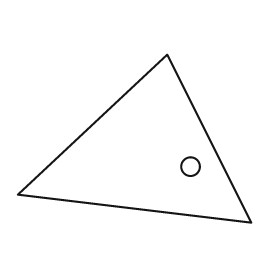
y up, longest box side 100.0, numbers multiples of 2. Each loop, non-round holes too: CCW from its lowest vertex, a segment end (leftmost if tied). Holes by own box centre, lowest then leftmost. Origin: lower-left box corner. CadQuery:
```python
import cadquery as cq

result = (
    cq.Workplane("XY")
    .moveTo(100.0, 0.0)
    .lineTo(64.0, 72.0)
    .lineTo(0.0, 12.0)
    .close()
    .moveTo(74.0, 24.0)
    .circle(4.0)
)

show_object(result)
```